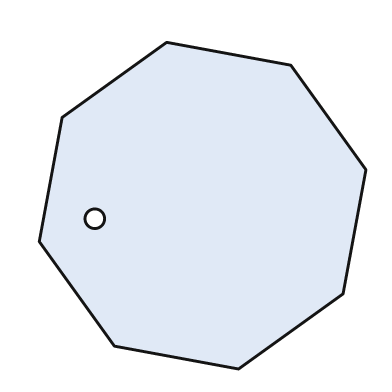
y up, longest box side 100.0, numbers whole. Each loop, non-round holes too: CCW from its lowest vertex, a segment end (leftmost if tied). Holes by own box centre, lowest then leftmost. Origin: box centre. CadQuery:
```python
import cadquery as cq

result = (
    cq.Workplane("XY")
    .moveTo(11.0, -50.0)
    .lineTo(43.0, -27.0)
    .lineTo(50.0, 11.0)
    .lineTo(27.0, 43.0)
    .lineTo(-11.0, 50.0)
    .lineTo(-43.0, 27.0)
    .lineTo(-50.0, -11.0)
    .lineTo(-27.0, -43.0)
    .close()
    .moveTo(-33.0, -4.0)
    .circle(3.0)
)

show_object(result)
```